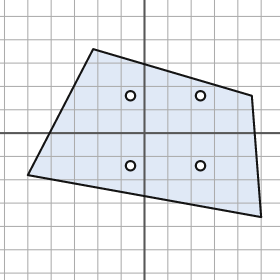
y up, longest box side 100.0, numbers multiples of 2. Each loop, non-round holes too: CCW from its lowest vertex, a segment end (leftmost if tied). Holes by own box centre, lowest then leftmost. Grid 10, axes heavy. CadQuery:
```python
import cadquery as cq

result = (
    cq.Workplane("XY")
    .moveTo(50.0, -36.0)
    .lineTo(46.0, 16.0)
    .lineTo(-22.0, 36.0)
    .lineTo(-50.0, -18.0)
    .close()
    .moveTo(-6.0, -14.0)
    .circle(2.0)
    .moveTo(24.0, -14.0)
    .circle(2.0)
    .moveTo(-6.0, 16.0)
    .circle(2.0)
    .moveTo(24.0, 16.0)
    .circle(2.0)
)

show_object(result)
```